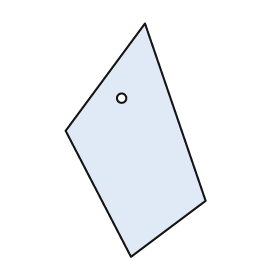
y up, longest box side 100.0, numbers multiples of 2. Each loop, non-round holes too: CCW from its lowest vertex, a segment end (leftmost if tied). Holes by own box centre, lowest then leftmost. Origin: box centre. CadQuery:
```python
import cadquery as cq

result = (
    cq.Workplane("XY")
    .moveTo(-2.0, -50.0)
    .lineTo(30.0, -26.0)
    .lineTo(4.0, 50.0)
    .lineTo(-30.0, 4.0)
    .close()
    .moveTo(-6.0, 18.0)
    .circle(2.0)
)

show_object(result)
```